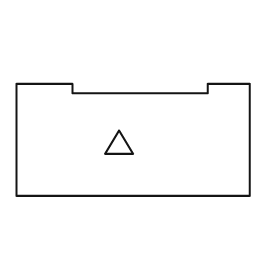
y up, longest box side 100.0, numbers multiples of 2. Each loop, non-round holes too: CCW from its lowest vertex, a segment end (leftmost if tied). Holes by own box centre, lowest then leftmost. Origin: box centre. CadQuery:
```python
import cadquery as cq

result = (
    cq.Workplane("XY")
    .moveTo(-50.0, -24.0)
    .lineTo(50.0, -24.0)
    .lineTo(50.0, 24.0)
    .lineTo(32.0, 24.0)
    .lineTo(32.0, 20.0)
    .lineTo(-26.0, 20.0)
    .lineTo(-26.0, 24.0)
    .lineTo(-50.0, 24.0)
    .close()
    .moveTo(-12.0, -6.0)
    .lineTo(0.0, -6.0)
    .lineTo(-6.0, 4.0)
    .close()
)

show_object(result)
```